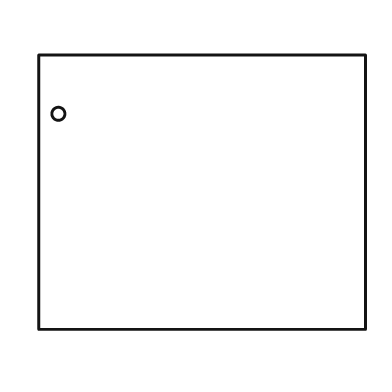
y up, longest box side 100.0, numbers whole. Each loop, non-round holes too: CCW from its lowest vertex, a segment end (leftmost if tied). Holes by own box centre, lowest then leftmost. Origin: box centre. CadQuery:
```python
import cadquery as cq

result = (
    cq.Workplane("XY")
    .moveTo(-50.0, -42.0)
    .lineTo(50.0, -42.0)
    .lineTo(50.0, 42.0)
    .lineTo(-50.0, 42.0)
    .close()
    .moveTo(-44.0, 24.0)
    .circle(2.0)
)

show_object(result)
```